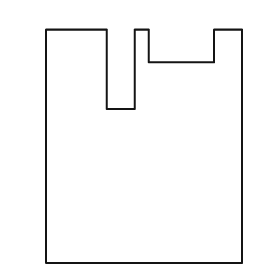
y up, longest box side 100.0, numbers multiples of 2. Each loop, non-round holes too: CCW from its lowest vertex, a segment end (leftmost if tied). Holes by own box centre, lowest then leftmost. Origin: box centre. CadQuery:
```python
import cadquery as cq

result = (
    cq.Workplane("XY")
    .moveTo(-42.0, -50.0)
    .lineTo(42.0, -50.0)
    .lineTo(42.0, 50.0)
    .lineTo(30.0, 50.0)
    .lineTo(30.0, 36.0)
    .lineTo(2.0, 36.0)
    .lineTo(2.0, 50.0)
    .lineTo(-4.0, 50.0)
    .lineTo(-4.0, 16.0)
    .lineTo(-16.0, 16.0)
    .lineTo(-16.0, 50.0)
    .lineTo(-42.0, 50.0)
    .close()
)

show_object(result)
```